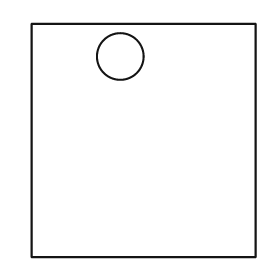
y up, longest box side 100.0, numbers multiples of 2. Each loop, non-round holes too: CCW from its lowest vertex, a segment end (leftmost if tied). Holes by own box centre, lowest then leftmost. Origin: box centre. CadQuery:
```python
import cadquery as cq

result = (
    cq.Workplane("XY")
    .moveTo(-48.0, -50.0)
    .lineTo(48.0, -50.0)
    .lineTo(48.0, 50.0)
    .lineTo(-48.0, 50.0)
    .close()
    .moveTo(-10.0, 36.0)
    .circle(10.0)
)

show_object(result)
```